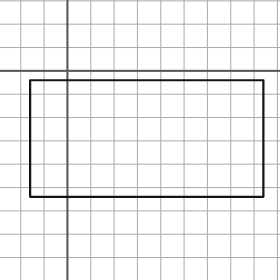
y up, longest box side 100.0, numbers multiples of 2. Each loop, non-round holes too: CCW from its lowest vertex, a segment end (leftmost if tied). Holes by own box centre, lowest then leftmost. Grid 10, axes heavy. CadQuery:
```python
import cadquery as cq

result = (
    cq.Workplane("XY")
    .moveTo(-16.0, -54.0)
    .lineTo(84.0, -54.0)
    .lineTo(84.0, -4.0)
    .lineTo(-16.0, -4.0)
    .close()
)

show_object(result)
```